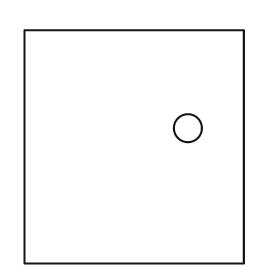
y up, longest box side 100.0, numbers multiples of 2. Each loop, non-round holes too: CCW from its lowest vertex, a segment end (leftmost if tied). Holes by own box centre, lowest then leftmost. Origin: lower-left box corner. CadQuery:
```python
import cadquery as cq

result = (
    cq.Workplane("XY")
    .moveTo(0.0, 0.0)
    .lineTo(94.0, 0.0)
    .lineTo(94.0, 100.0)
    .lineTo(0.0, 100.0)
    .close()
    .moveTo(70.0, 58.0)
    .circle(6.0)
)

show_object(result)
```